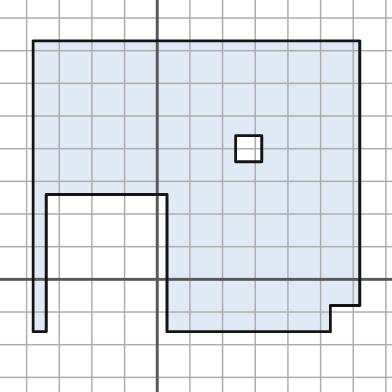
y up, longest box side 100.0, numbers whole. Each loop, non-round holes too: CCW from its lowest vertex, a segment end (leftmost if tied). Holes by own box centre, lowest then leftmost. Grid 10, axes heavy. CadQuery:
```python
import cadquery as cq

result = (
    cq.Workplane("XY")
    .moveTo(-38.0, -16.0)
    .lineTo(-34.0, -16.0)
    .lineTo(-34.0, 26.0)
    .lineTo(3.0, 26.0)
    .lineTo(3.0, -16.0)
    .lineTo(53.0, -16.0)
    .lineTo(53.0, -8.0)
    .lineTo(62.0, -8.0)
    .lineTo(62.0, 73.0)
    .lineTo(-38.0, 73.0)
    .close()
    .moveTo(24.0, 36.0)
    .lineTo(32.0, 36.0)
    .lineTo(32.0, 44.0)
    .lineTo(24.0, 44.0)
    .close()
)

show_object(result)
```